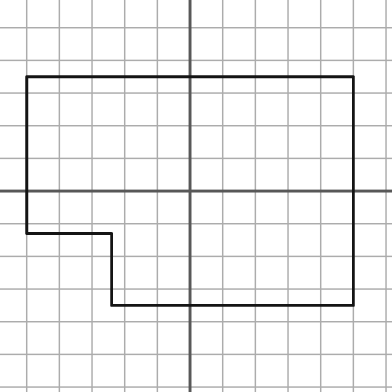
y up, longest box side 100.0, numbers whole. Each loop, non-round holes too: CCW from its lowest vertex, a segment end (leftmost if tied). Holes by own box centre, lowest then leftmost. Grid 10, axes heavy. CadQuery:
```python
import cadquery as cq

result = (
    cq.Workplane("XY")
    .moveTo(-24.0, -35.0)
    .lineTo(50.0, -35.0)
    .lineTo(50.0, 35.0)
    .lineTo(-50.0, 35.0)
    .lineTo(-50.0, -13.0)
    .lineTo(-24.0, -13.0)
    .close()
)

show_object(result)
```